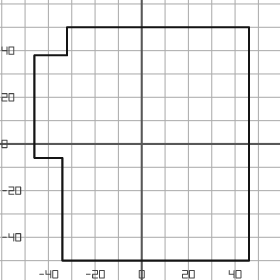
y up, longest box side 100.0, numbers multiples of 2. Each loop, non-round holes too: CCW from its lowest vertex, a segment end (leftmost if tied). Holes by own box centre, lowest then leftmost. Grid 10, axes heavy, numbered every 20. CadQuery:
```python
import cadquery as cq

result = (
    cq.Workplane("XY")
    .moveTo(-34.0, -50.0)
    .lineTo(46.0, -50.0)
    .lineTo(46.0, 50.0)
    .lineTo(-32.0, 50.0)
    .lineTo(-32.0, 38.0)
    .lineTo(-46.0, 38.0)
    .lineTo(-46.0, -6.0)
    .lineTo(-34.0, -6.0)
    .close()
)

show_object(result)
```